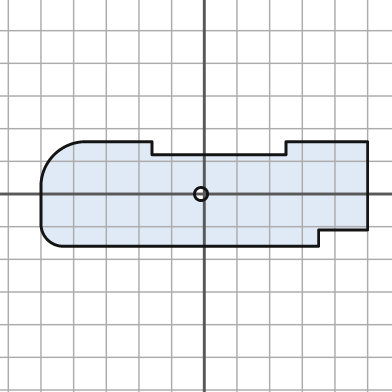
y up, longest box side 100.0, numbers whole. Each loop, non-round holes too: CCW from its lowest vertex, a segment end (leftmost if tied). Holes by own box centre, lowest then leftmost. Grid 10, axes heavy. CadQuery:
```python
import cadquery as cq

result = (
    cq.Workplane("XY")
    .moveTo(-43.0, -16.0)
    .lineTo(35.0, -16.0)
    .lineTo(35.0, -11.0)
    .lineTo(50.0, -11.0)
    .lineTo(50.0, 16.0)
    .lineTo(25.0, 16.0)
    .lineTo(25.0, 12.0)
    .lineTo(-16.0, 12.0)
    .lineTo(-16.0, 16.0)
    .lineTo(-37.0, 16.0)
    .threePointArc((-46.0, 12.0), (-50.0, 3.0))
    .lineTo(-50.0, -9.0)
    .threePointArc((-48.0, -14.0), (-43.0, -16.0))
    .close()
    .moveTo(-1.0, 0.0)
    .circle(2.0)
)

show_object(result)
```